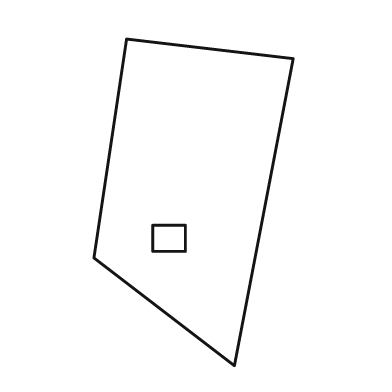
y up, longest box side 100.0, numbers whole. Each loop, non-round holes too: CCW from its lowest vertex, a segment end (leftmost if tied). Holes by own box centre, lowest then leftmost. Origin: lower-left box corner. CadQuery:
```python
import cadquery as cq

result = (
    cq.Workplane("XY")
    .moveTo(43.0, 0.0)
    .lineTo(61.0, 94.0)
    .lineTo(10.0, 100.0)
    .lineTo(0.0, 33.0)
    .close()
    .moveTo(18.0, 35.0)
    .lineTo(28.0, 35.0)
    .lineTo(28.0, 43.0)
    .lineTo(18.0, 43.0)
    .close()
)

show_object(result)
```